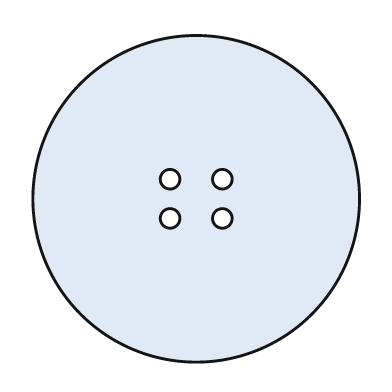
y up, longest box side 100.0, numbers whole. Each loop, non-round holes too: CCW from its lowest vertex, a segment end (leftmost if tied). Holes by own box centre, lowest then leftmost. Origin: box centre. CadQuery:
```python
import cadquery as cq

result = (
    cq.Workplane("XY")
    .moveTo(0.0, 0.0)
    .circle(50.0)
    .moveTo(-8.0, -6.0)
    .circle(3.0)
    .moveTo(8.0, -6.0)
    .circle(3.0)
    .moveTo(-8.0, 6.0)
    .circle(3.0)
    .moveTo(8.0, 6.0)
    .circle(3.0)
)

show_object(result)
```